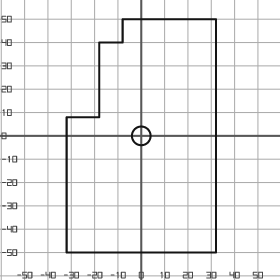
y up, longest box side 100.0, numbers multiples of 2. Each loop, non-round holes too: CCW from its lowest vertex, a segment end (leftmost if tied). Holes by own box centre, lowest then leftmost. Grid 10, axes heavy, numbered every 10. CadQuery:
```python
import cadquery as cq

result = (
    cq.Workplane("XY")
    .moveTo(-32.0, -50.0)
    .lineTo(32.0, -50.0)
    .lineTo(32.0, 50.0)
    .lineTo(-8.0, 50.0)
    .lineTo(-8.0, 40.0)
    .lineTo(-18.0, 40.0)
    .lineTo(-18.0, 8.0)
    .lineTo(-32.0, 8.0)
    .close()
    .moveTo(0.0, 0.0)
    .circle(4.0)
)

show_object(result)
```